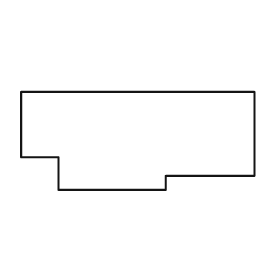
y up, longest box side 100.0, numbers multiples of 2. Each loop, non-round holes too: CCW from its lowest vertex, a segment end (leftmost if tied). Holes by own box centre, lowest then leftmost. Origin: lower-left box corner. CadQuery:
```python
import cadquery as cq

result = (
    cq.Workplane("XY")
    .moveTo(16.0, 0.0)
    .lineTo(62.0, 0.0)
    .lineTo(62.0, 6.0)
    .lineTo(100.0, 6.0)
    .lineTo(100.0, 42.0)
    .lineTo(0.0, 42.0)
    .lineTo(0.0, 14.0)
    .lineTo(16.0, 14.0)
    .close()
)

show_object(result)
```